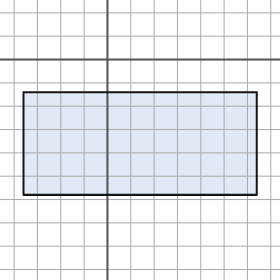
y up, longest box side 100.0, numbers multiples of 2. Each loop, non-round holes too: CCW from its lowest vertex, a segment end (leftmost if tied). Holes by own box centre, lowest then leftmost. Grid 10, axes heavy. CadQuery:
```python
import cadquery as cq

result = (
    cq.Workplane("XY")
    .moveTo(-36.0, -58.0)
    .lineTo(64.0, -58.0)
    .lineTo(64.0, -14.0)
    .lineTo(-36.0, -14.0)
    .close()
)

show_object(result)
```